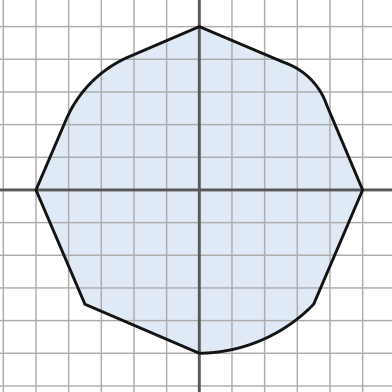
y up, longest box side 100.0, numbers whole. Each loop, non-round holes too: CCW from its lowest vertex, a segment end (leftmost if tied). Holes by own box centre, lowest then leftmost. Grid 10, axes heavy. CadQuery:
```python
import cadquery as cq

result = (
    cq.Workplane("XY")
    .moveTo(0.0, -50.0)
    .threePointArc((19.0, -46.0), (35.0, -35.0))
    .lineTo(50.0, 0.0)
    .lineTo(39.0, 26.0)
    .threePointArc((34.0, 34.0), (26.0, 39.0))
    .lineTo(0.0, 50.0)
    .lineTo(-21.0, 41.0)
    .threePointArc((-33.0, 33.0), (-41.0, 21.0))
    .lineTo(-50.0, 0.0)
    .lineTo(-35.0, -35.0)
    .close()
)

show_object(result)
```